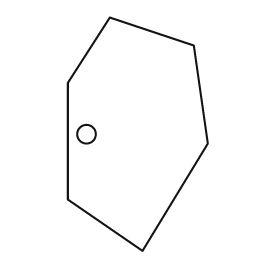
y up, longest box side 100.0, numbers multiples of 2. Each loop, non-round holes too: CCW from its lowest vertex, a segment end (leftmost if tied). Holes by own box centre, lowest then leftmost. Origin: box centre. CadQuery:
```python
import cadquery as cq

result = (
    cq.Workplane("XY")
    .moveTo(2.0, -50.0)
    .lineTo(30.0, -4.0)
    .lineTo(24.0, 38.0)
    .lineTo(-12.0, 50.0)
    .lineTo(-30.0, 22.0)
    .lineTo(-30.0, -28.0)
    .close()
    .moveTo(-22.0, 0.0)
    .circle(4.0)
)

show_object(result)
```